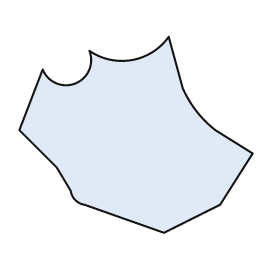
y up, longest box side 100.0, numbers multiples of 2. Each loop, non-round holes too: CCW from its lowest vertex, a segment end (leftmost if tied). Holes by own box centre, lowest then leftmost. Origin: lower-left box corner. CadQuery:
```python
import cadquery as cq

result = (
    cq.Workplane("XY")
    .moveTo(62.0, 0.0)
    .lineTo(86.0, 12.0)
    .lineTo(100.0, 34.0)
    .lineTo(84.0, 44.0)
    .threePointArc((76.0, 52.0), (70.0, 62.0))
    .lineTo(64.0, 84.0)
    .threePointArc((48.0, 74.0), (30.0, 78.0))
    .threePointArc((24.0, 64.0), (10.0, 70.0))
    .lineTo(0.0, 44.0)
    .lineTo(16.0, 28.0)
    .lineTo(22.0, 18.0)
    .threePointArc((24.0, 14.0), (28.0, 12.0))
    .close()
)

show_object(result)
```